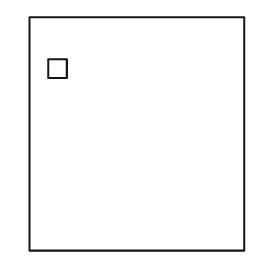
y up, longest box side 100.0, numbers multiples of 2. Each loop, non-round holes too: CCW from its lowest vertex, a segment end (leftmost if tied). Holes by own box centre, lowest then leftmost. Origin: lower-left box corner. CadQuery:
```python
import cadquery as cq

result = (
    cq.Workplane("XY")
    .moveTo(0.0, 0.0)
    .lineTo(92.0, 0.0)
    .lineTo(92.0, 100.0)
    .lineTo(0.0, 100.0)
    .close()
    .moveTo(8.0, 74.0)
    .lineTo(16.0, 74.0)
    .lineTo(16.0, 82.0)
    .lineTo(8.0, 82.0)
    .close()
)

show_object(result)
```